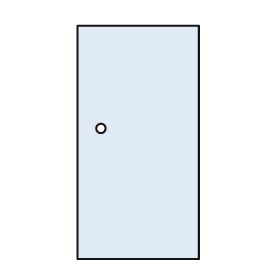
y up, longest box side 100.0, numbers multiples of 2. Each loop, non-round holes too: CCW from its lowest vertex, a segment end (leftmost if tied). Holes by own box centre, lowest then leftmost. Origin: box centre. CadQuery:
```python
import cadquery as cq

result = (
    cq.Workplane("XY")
    .moveTo(-26.0, -50.0)
    .lineTo(26.0, -50.0)
    .lineTo(26.0, 50.0)
    .lineTo(-26.0, 50.0)
    .close()
    .moveTo(-16.0, 6.0)
    .circle(2.0)
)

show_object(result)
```